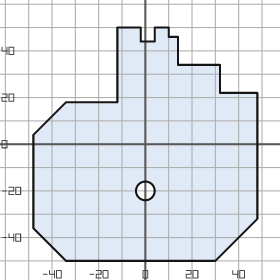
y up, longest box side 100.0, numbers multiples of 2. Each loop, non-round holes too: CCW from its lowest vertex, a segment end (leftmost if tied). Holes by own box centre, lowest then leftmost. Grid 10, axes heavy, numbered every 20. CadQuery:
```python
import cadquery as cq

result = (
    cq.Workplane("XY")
    .moveTo(-34.0, -50.0)
    .lineTo(30.0, -50.0)
    .lineTo(48.0, -32.0)
    .lineTo(48.0, 22.0)
    .lineTo(32.0, 22.0)
    .lineTo(32.0, 34.0)
    .lineTo(14.0, 34.0)
    .lineTo(14.0, 46.0)
    .lineTo(10.0, 46.0)
    .lineTo(10.0, 50.0)
    .lineTo(4.0, 50.0)
    .lineTo(4.0, 44.0)
    .lineTo(-2.0, 44.0)
    .lineTo(-2.0, 50.0)
    .lineTo(-12.0, 50.0)
    .lineTo(-12.0, 18.0)
    .lineTo(-34.0, 18.0)
    .lineTo(-48.0, 4.0)
    .lineTo(-48.0, -36.0)
    .close()
    .moveTo(0.0, -20.0)
    .circle(4.0)
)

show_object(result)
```